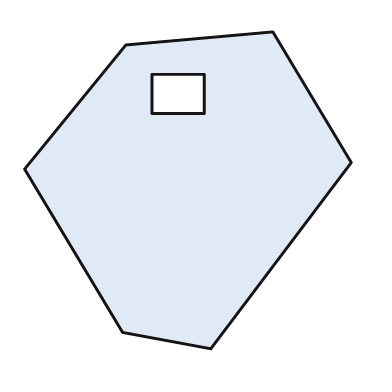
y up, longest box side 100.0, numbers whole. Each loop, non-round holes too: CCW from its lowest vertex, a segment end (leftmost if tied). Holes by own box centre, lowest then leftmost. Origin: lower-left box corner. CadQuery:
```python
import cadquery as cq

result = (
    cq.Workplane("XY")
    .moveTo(57.0, 0.0)
    .lineTo(100.0, 57.0)
    .lineTo(76.0, 97.0)
    .lineTo(31.0, 93.0)
    .lineTo(0.0, 55.0)
    .lineTo(30.0, 5.0)
    .close()
    .moveTo(39.0, 72.0)
    .lineTo(55.0, 72.0)
    .lineTo(55.0, 84.0)
    .lineTo(39.0, 84.0)
    .close()
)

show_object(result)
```